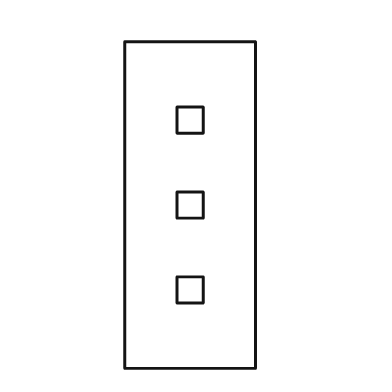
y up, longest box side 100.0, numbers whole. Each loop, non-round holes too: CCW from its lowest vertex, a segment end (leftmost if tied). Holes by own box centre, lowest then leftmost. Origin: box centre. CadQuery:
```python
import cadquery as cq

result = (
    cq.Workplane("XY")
    .moveTo(-20.0, -50.0)
    .lineTo(20.0, -50.0)
    .lineTo(20.0, 50.0)
    .lineTo(-20.0, 50.0)
    .close()
    .moveTo(-4.0, -30.0)
    .lineTo(4.0, -30.0)
    .lineTo(4.0, -22.0)
    .lineTo(-4.0, -22.0)
    .close()
    .moveTo(-4.0, -4.0)
    .lineTo(4.0, -4.0)
    .lineTo(4.0, 4.0)
    .lineTo(-4.0, 4.0)
    .close()
    .moveTo(-4.0, 22.0)
    .lineTo(4.0, 22.0)
    .lineTo(4.0, 30.0)
    .lineTo(-4.0, 30.0)
    .close()
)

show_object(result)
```